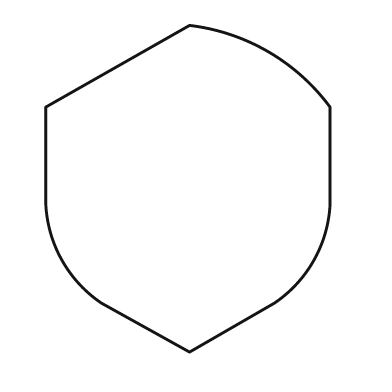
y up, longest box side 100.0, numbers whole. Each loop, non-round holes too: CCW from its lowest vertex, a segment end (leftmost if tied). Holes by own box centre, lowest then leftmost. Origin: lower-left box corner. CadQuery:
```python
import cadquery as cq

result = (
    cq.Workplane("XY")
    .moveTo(44.0, 0.0)
    .lineTo(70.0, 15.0)
    .threePointArc((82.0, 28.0), (87.0, 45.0))
    .lineTo(87.0, 75.0)
    .threePointArc((68.0, 92.0), (44.0, 100.0))
    .lineTo(0.0, 75.0)
    .lineTo(0.0, 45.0)
    .threePointArc((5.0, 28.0), (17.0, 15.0))
    .close()
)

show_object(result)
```